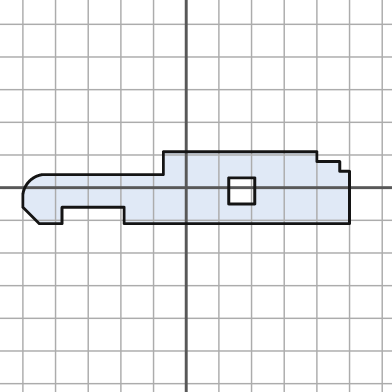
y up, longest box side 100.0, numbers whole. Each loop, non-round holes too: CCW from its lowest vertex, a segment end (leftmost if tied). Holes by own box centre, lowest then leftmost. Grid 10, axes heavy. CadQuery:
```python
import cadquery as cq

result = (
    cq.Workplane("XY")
    .moveTo(-45.0, -11.0)
    .lineTo(-38.0, -11.0)
    .lineTo(-38.0, -6.0)
    .lineTo(-19.0, -6.0)
    .lineTo(-19.0, -11.0)
    .lineTo(50.0, -11.0)
    .lineTo(50.0, 5.0)
    .lineTo(47.0, 5.0)
    .lineTo(47.0, 8.0)
    .lineTo(40.0, 8.0)
    .lineTo(40.0, 11.0)
    .lineTo(-7.0, 11.0)
    .lineTo(-7.0, 4.0)
    .lineTo(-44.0, 4.0)
    .threePointArc((-48.0, 2.0), (-50.0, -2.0))
    .lineTo(-50.0, -6.0)
    .close()
    .moveTo(13.0, -5.0)
    .lineTo(21.0, -5.0)
    .lineTo(21.0, 3.0)
    .lineTo(13.0, 3.0)
    .close()
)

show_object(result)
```